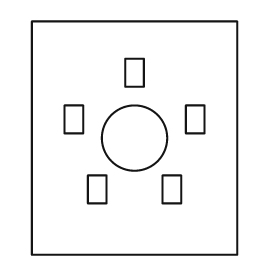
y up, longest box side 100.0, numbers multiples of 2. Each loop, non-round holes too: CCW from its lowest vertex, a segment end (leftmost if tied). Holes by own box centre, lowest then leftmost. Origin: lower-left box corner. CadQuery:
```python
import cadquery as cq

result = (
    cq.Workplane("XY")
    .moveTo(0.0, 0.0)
    .lineTo(88.0, 0.0)
    .lineTo(88.0, 100.0)
    .lineTo(0.0, 100.0)
    .close()
    .moveTo(24.0, 22.0)
    .lineTo(32.0, 22.0)
    .lineTo(32.0, 34.0)
    .lineTo(24.0, 34.0)
    .close()
    .moveTo(56.0, 22.0)
    .lineTo(64.0, 22.0)
    .lineTo(64.0, 34.0)
    .lineTo(56.0, 34.0)
    .close()
    .moveTo(44.0, 50.0)
    .circle(14.0)
    .moveTo(14.0, 52.0)
    .lineTo(22.0, 52.0)
    .lineTo(22.0, 64.0)
    .lineTo(14.0, 64.0)
    .close()
    .moveTo(66.0, 52.0)
    .lineTo(74.0, 52.0)
    .lineTo(74.0, 64.0)
    .lineTo(66.0, 64.0)
    .close()
    .moveTo(40.0, 72.0)
    .lineTo(48.0, 72.0)
    .lineTo(48.0, 84.0)
    .lineTo(40.0, 84.0)
    .close()
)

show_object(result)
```